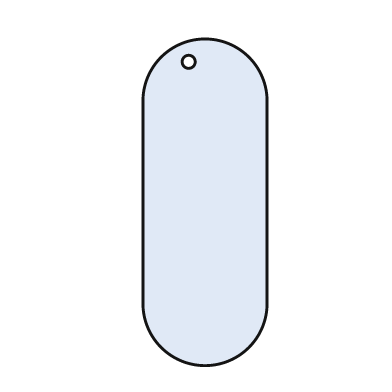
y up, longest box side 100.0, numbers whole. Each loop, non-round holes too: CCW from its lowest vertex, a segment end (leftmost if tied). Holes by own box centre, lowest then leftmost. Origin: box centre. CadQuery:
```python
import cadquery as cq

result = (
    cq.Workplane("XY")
    .moveTo(-19.0, -31.0)
    .threePointArc((0.0, -50.0), (19.0, -31.0))
    .lineTo(19.0, 31.0)
    .threePointArc((0.0, 50.0), (-19.0, 31.0))
    .close()
    .moveTo(-5.0, 43.0)
    .circle(2.0)
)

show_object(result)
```